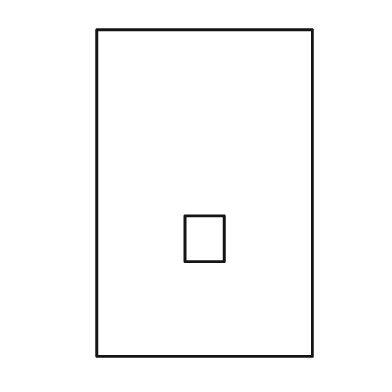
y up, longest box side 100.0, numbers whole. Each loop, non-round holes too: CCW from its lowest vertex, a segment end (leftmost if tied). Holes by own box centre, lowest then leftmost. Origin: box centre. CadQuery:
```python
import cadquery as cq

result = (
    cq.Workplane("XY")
    .moveTo(-33.0, -50.0)
    .lineTo(33.0, -50.0)
    .lineTo(33.0, 50.0)
    .lineTo(-33.0, 50.0)
    .close()
    .moveTo(-6.0, -21.0)
    .lineTo(6.0, -21.0)
    .lineTo(6.0, -7.0)
    .lineTo(-6.0, -7.0)
    .close()
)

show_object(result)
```